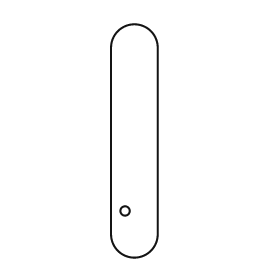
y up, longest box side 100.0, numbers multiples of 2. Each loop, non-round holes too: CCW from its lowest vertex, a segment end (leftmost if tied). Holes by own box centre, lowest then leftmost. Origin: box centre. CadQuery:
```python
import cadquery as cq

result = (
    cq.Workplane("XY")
    .moveTo(-10.0, -40.0)
    .threePointArc((0.0, -50.0), (10.0, -40.0))
    .lineTo(10.0, 40.0)
    .threePointArc((0.0, 50.0), (-10.0, 40.0))
    .close()
    .moveTo(-4.0, -30.0)
    .circle(2.0)
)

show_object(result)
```